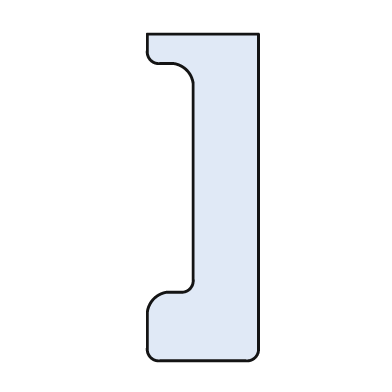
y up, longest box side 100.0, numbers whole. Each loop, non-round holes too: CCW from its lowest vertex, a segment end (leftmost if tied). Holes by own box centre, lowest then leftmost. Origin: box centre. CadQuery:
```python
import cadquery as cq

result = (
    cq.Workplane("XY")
    .moveTo(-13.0, -50.0)
    .lineTo(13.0, -50.0)
    .threePointArc((16.0, -49.0), (17.0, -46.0))
    .lineTo(17.0, 50.0)
    .lineTo(-17.0, 50.0)
    .lineTo(-17.0, 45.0)
    .threePointArc((-16.0, 42.0), (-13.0, 41.0))
    .lineTo(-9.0, 41.0)
    .threePointArc((-5.0, 39.0), (-3.0, 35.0))
    .lineTo(-3.0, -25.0)
    .threePointArc((-4.0, -28.0), (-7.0, -29.0))
    .lineTo(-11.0, -29.0)
    .threePointArc((-15.0, -31.0), (-17.0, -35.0))
    .lineTo(-17.0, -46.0)
    .threePointArc((-16.0, -49.0), (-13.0, -50.0))
    .close()
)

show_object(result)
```